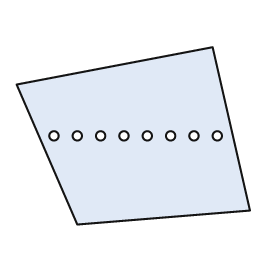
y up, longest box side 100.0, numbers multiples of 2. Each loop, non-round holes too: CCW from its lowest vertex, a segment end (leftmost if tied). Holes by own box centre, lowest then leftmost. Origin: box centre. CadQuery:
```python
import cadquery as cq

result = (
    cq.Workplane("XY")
    .moveTo(-24.0, -38.0)
    .lineTo(50.0, -32.0)
    .lineTo(34.0, 38.0)
    .lineTo(-50.0, 22.0)
    .close()
    .moveTo(-34.0, 0.0)
    .circle(2.0)
    .moveTo(-24.0, 0.0)
    .circle(2.0)
    .moveTo(-14.0, 0.0)
    .circle(2.0)
    .moveTo(-4.0, 0.0)
    .circle(2.0)
    .moveTo(6.0, 0.0)
    .circle(2.0)
    .moveTo(16.0, 0.0)
    .circle(2.0)
    .moveTo(26.0, 0.0)
    .circle(2.0)
    .moveTo(36.0, 0.0)
    .circle(2.0)
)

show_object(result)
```